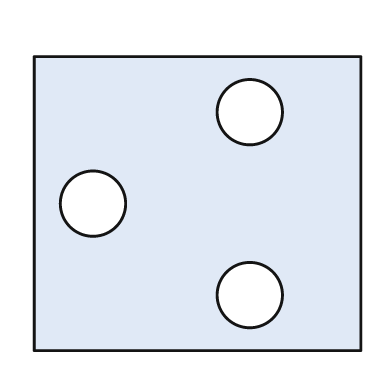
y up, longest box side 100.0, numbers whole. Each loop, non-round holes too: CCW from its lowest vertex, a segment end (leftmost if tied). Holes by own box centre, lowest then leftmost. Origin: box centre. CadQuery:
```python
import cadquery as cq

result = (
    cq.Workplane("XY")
    .moveTo(-50.0, -45.0)
    .lineTo(50.0, -45.0)
    .lineTo(50.0, 45.0)
    .lineTo(-50.0, 45.0)
    .close()
    .moveTo(16.0, -28.0)
    .circle(10.0)
    .moveTo(-32.0, 0.0)
    .circle(10.0)
    .moveTo(16.0, 28.0)
    .circle(10.0)
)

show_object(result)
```